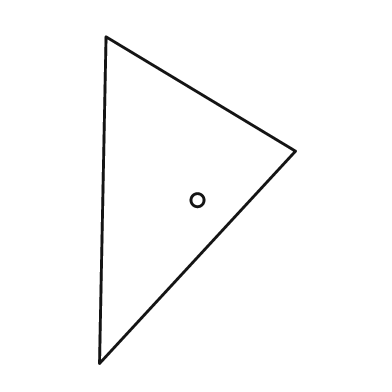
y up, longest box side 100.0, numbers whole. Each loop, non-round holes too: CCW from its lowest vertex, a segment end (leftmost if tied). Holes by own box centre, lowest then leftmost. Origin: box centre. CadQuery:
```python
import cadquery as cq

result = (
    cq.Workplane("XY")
    .moveTo(-30.0, -50.0)
    .lineTo(30.0, 15.0)
    .lineTo(-28.0, 50.0)
    .close()
    .moveTo(0.0, 0.0)
    .circle(2.0)
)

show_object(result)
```